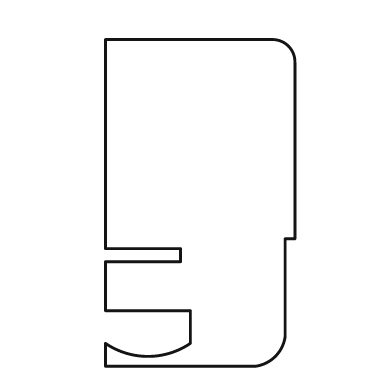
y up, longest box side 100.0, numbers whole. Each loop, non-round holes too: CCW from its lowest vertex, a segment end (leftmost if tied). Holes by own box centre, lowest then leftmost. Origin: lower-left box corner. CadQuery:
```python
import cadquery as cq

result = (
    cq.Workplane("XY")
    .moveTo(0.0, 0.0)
    .lineTo(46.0, 0.0)
    .threePointArc((52.0, 3.0), (55.0, 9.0))
    .lineTo(55.0, 39.0)
    .lineTo(58.0, 39.0)
    .lineTo(58.0, 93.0)
    .threePointArc((56.0, 98.0), (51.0, 100.0))
    .lineTo(0.0, 100.0)
    .lineTo(0.0, 36.0)
    .lineTo(23.0, 36.0)
    .lineTo(23.0, 32.0)
    .lineTo(0.0, 32.0)
    .lineTo(0.0, 17.0)
    .lineTo(26.0, 17.0)
    .lineTo(26.0, 7.0)
    .threePointArc((13.0, 3.0), (0.0, 7.0))
    .close()
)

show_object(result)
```